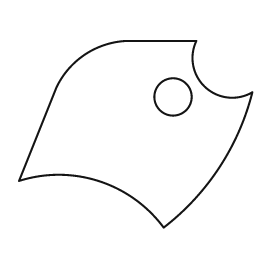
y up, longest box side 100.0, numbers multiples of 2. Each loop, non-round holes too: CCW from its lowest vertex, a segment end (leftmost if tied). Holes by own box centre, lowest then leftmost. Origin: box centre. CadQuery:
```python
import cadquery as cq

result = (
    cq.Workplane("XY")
    .moveTo(12.0, -40.0)
    .threePointArc((36.0, -14.0), (50.0, 18.0))
    .threePointArc((30.0, 20.0), (26.0, 40.0))
    .lineTo(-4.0, 40.0)
    .threePointArc((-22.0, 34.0), (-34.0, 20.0))
    .lineTo(-50.0, -20.0)
    .threePointArc((-16.0, -20.0), (12.0, -40.0))
    .close()
    .moveTo(16.0, 16.0)
    .circle(8.0)
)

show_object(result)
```